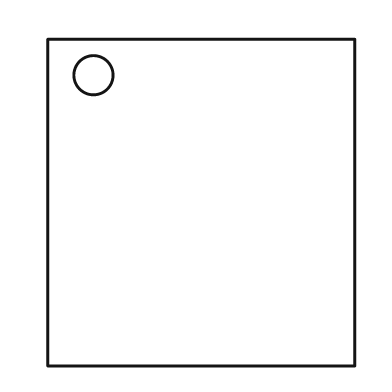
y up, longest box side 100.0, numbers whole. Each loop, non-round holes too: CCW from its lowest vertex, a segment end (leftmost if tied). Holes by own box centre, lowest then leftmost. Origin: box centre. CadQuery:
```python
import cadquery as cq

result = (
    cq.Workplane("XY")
    .moveTo(-47.0, -50.0)
    .lineTo(47.0, -50.0)
    .lineTo(47.0, 50.0)
    .lineTo(-47.0, 50.0)
    .close()
    .moveTo(-33.0, 39.0)
    .circle(6.0)
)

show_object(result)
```